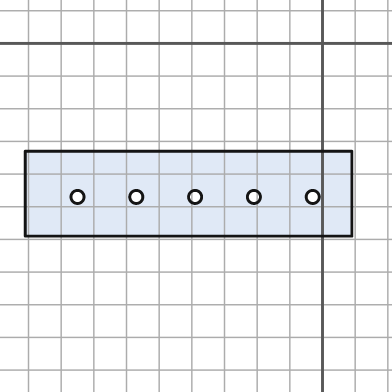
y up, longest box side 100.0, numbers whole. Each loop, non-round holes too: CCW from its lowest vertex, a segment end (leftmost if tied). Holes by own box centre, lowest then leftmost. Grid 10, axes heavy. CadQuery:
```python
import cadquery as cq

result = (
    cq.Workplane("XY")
    .moveTo(-91.0, -59.0)
    .lineTo(9.0, -59.0)
    .lineTo(9.0, -33.0)
    .lineTo(-91.0, -33.0)
    .close()
    .moveTo(-75.0, -47.0)
    .circle(2.0)
    .moveTo(-57.0, -47.0)
    .circle(2.0)
    .moveTo(-39.0, -47.0)
    .circle(2.0)
    .moveTo(-21.0, -47.0)
    .circle(2.0)
    .moveTo(-3.0, -47.0)
    .circle(2.0)
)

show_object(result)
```